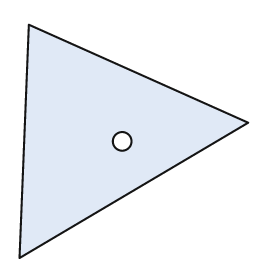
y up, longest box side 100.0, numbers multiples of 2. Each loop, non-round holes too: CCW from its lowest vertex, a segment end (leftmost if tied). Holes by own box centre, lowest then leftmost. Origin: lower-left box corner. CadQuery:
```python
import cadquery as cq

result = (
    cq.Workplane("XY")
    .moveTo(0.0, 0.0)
    .lineTo(98.0, 58.0)
    .lineTo(4.0, 100.0)
    .close()
    .moveTo(44.0, 50.0)
    .circle(4.0)
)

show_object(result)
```